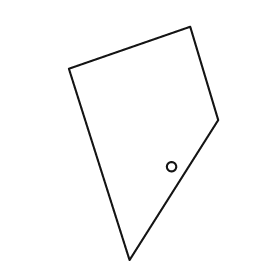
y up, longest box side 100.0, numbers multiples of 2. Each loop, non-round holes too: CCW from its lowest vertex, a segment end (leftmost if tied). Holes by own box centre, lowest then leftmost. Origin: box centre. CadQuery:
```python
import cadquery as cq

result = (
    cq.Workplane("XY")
    .moveTo(-6.0, -50.0)
    .lineTo(32.0, 10.0)
    .lineTo(20.0, 50.0)
    .lineTo(-32.0, 32.0)
    .close()
    .moveTo(12.0, -10.0)
    .circle(2.0)
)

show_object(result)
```